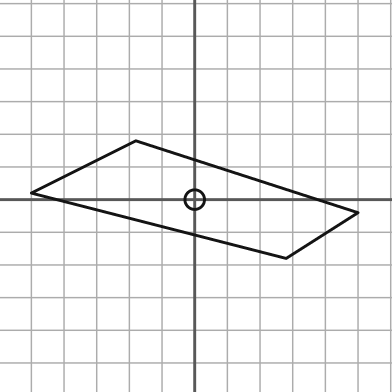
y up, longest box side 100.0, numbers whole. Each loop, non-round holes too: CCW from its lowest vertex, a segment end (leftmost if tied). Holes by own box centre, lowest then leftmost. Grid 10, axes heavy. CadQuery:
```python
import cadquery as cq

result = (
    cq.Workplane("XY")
    .moveTo(28.0, -18.0)
    .lineTo(50.0, -4.0)
    .lineTo(-18.0, 18.0)
    .lineTo(-50.0, 2.0)
    .close()
    .moveTo(0.0, 0.0)
    .circle(3.0)
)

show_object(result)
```